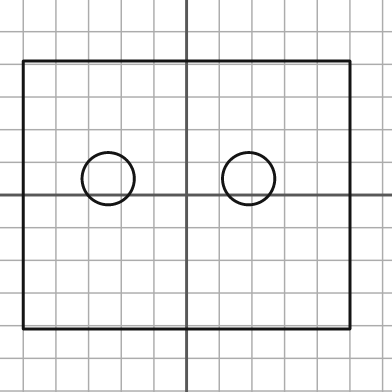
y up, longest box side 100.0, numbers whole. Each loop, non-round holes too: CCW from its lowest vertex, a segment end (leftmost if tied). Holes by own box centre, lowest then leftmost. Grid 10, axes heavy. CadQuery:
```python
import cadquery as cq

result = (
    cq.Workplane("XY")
    .moveTo(-50.0, -41.0)
    .lineTo(50.0, -41.0)
    .lineTo(50.0, 41.0)
    .lineTo(-50.0, 41.0)
    .close()
    .moveTo(-24.0, 5.0)
    .circle(8.0)
    .moveTo(19.0, 5.0)
    .circle(8.0)
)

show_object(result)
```